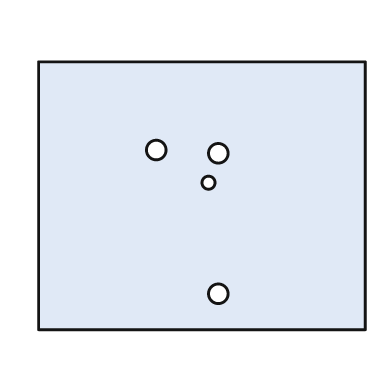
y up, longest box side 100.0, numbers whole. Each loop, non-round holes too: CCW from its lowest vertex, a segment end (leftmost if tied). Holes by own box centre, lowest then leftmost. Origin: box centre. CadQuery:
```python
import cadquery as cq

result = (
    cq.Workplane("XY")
    .moveTo(-50.0, -41.0)
    .lineTo(50.0, -41.0)
    .lineTo(50.0, 41.0)
    .lineTo(-50.0, 41.0)
    .close()
    .moveTo(5.0, -30.0)
    .circle(3.0)
    .moveTo(2.0, 4.0)
    .circle(2.0)
    .moveTo(5.0, 13.0)
    .circle(3.0)
    .moveTo(-14.0, 14.0)
    .circle(3.0)
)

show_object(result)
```